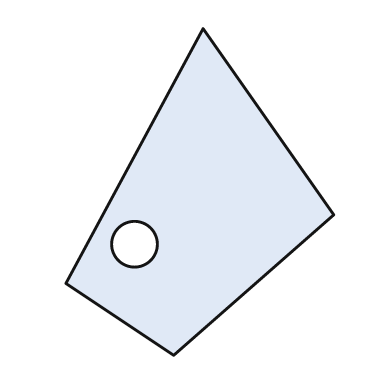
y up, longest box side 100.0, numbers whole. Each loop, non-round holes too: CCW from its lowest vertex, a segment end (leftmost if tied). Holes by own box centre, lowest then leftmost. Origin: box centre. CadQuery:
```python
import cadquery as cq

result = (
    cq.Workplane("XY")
    .moveTo(-8.0, -50.0)
    .lineTo(41.0, -7.0)
    .lineTo(1.0, 50.0)
    .lineTo(-41.0, -28.0)
    .close()
    .moveTo(-20.0, -16.0)
    .circle(7.0)
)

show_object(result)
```